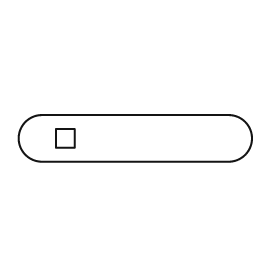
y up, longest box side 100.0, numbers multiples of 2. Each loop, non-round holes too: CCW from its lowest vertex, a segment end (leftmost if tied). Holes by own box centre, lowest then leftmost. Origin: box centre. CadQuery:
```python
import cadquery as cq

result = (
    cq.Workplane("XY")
    .moveTo(-40.0, -10.0)
    .lineTo(40.0, -10.0)
    .threePointArc((50.0, 0.0), (40.0, 10.0))
    .lineTo(-40.0, 10.0)
    .threePointArc((-50.0, 0.0), (-40.0, -10.0))
    .close()
    .moveTo(-34.0, -4.0)
    .lineTo(-26.0, -4.0)
    .lineTo(-26.0, 4.0)
    .lineTo(-34.0, 4.0)
    .close()
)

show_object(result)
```